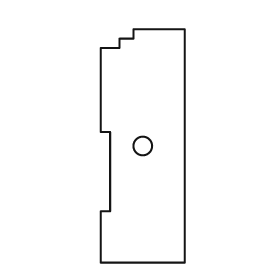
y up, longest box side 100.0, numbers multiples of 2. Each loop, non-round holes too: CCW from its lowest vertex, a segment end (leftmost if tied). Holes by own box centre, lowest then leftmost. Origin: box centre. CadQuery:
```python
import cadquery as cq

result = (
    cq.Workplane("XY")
    .moveTo(-18.0, -50.0)
    .lineTo(18.0, -50.0)
    .lineTo(18.0, 50.0)
    .lineTo(-4.0, 50.0)
    .lineTo(-4.0, 46.0)
    .lineTo(-10.0, 46.0)
    .lineTo(-10.0, 42.0)
    .lineTo(-18.0, 42.0)
    .lineTo(-18.0, 6.0)
    .lineTo(-14.0, 6.0)
    .lineTo(-14.0, -28.0)
    .lineTo(-18.0, -28.0)
    .close()
    .moveTo(0.0, 0.0)
    .circle(4.0)
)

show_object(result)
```